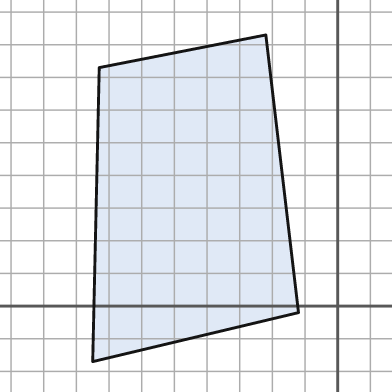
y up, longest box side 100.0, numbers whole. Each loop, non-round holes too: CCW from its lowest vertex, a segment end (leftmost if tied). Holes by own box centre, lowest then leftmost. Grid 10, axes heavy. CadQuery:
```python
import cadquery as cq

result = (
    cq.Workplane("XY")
    .moveTo(-75.0, -17.0)
    .lineTo(-12.0, -2.0)
    .lineTo(-22.0, 83.0)
    .lineTo(-73.0, 73.0)
    .close()
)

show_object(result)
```